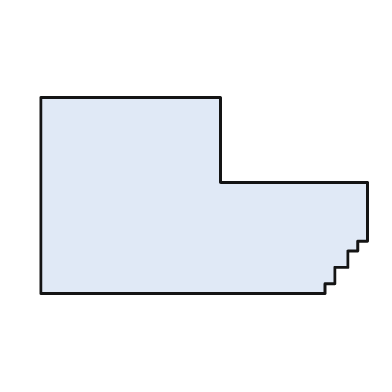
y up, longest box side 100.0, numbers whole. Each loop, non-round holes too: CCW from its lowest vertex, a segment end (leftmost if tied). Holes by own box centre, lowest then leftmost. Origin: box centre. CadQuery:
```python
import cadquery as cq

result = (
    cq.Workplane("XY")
    .moveTo(-50.0, -30.0)
    .lineTo(37.0, -30.0)
    .lineTo(37.0, -27.0)
    .lineTo(40.0, -27.0)
    .lineTo(40.0, -22.0)
    .lineTo(44.0, -22.0)
    .lineTo(44.0, -17.0)
    .lineTo(47.0, -17.0)
    .lineTo(47.0, -14.0)
    .lineTo(50.0, -14.0)
    .lineTo(50.0, 4.0)
    .lineTo(5.0, 4.0)
    .lineTo(5.0, 30.0)
    .lineTo(-50.0, 30.0)
    .close()
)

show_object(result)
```